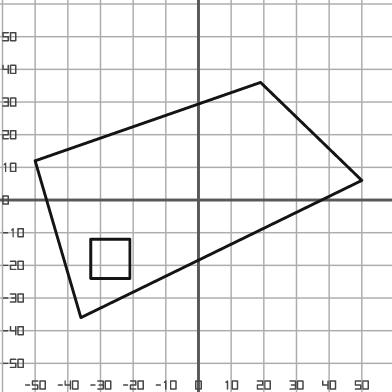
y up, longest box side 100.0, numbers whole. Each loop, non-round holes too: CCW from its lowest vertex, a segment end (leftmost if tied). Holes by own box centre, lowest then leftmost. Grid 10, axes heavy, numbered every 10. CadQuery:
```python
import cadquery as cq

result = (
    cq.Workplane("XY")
    .moveTo(-36.0, -36.0)
    .lineTo(50.0, 6.0)
    .lineTo(19.0, 36.0)
    .lineTo(-50.0, 12.0)
    .close()
    .moveTo(-33.0, -24.0)
    .lineTo(-21.0, -24.0)
    .lineTo(-21.0, -12.0)
    .lineTo(-33.0, -12.0)
    .close()
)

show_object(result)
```